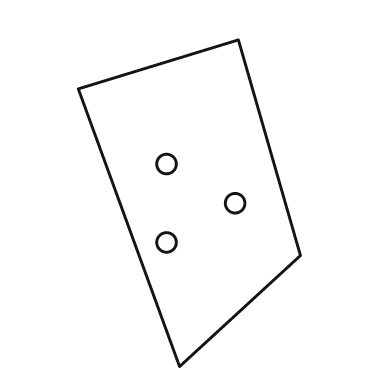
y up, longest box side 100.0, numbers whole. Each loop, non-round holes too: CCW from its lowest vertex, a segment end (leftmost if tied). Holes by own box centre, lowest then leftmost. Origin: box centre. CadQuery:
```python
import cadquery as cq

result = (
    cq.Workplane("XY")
    .moveTo(-3.0, -50.0)
    .lineTo(34.0, -16.0)
    .lineTo(15.0, 50.0)
    .lineTo(-34.0, 35.0)
    .close()
    .moveTo(-7.0, -12.0)
    .circle(3.0)
    .moveTo(14.0, 0.0)
    .circle(3.0)
    .moveTo(-7.0, 12.0)
    .circle(3.0)
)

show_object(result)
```